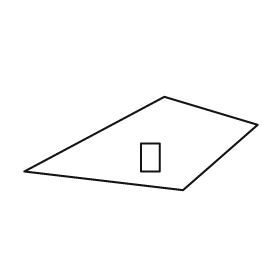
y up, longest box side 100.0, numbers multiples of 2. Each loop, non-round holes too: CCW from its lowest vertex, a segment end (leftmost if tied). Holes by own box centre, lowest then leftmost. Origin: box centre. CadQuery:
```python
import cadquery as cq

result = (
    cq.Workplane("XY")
    .moveTo(18.0, -20.0)
    .lineTo(50.0, 8.0)
    .lineTo(10.0, 20.0)
    .lineTo(-50.0, -12.0)
    .close()
    .moveTo(0.0, -12.0)
    .lineTo(8.0, -12.0)
    .lineTo(8.0, 0.0)
    .lineTo(0.0, 0.0)
    .close()
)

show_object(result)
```